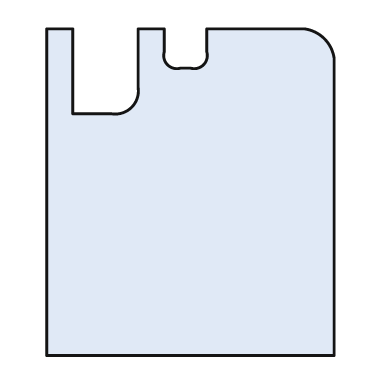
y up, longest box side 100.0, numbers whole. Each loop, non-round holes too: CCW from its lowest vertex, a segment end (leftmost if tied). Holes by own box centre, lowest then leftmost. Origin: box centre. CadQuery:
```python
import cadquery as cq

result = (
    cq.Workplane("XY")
    .moveTo(-44.0, -50.0)
    .lineTo(44.0, -50.0)
    .lineTo(44.0, 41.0)
    .threePointArc((41.0, 47.0), (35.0, 50.0))
    .lineTo(5.0, 50.0)
    .lineTo(5.0, 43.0)
    .threePointArc((4.0, 39.0), (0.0, 38.0))
    .lineTo(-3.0, 38.0)
    .threePointArc((-7.0, 39.0), (-8.0, 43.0))
    .lineTo(-8.0, 50.0)
    .lineTo(-16.0, 50.0)
    .lineTo(-16.0, 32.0)
    .threePointArc((-18.0, 26.0), (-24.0, 24.0))
    .lineTo(-36.0, 24.0)
    .lineTo(-36.0, 50.0)
    .lineTo(-44.0, 50.0)
    .close()
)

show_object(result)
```